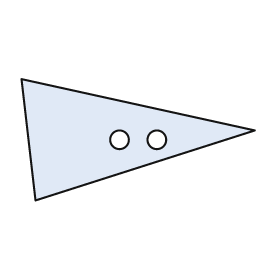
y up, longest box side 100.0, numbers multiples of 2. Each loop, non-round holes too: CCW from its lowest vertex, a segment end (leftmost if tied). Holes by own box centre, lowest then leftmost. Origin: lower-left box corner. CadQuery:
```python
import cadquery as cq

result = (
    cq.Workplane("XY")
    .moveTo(6.0, 0.0)
    .lineTo(100.0, 30.0)
    .lineTo(0.0, 52.0)
    .close()
    .moveTo(42.0, 26.0)
    .circle(4.0)
    .moveTo(58.0, 26.0)
    .circle(4.0)
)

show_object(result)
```